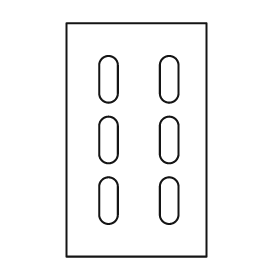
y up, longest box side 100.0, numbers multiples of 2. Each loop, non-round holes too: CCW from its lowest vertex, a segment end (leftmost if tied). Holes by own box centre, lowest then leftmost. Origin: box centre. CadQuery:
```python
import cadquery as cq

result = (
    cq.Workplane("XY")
    .moveTo(-30.0, -50.0)
    .lineTo(30.0, -50.0)
    .lineTo(30.0, 50.0)
    .lineTo(-30.0, 50.0)
    .close()
    .moveTo(-16.0, -32.0)
    .threePointArc((-12.0, -36.0), (-8.0, -32.0))
    .lineTo(-8.0, -20.0)
    .threePointArc((-12.0, -16.0), (-16.0, -20.0))
    .close()
    .moveTo(10.0, -32.0)
    .threePointArc((14.0, -36.0), (18.0, -32.0))
    .lineTo(18.0, -20.0)
    .threePointArc((14.0, -16.0), (10.0, -20.0))
    .close()
    .moveTo(-16.0, -6.0)
    .threePointArc((-12.0, -10.0), (-8.0, -6.0))
    .lineTo(-8.0, 6.0)
    .threePointArc((-12.0, 10.0), (-16.0, 6.0))
    .close()
    .moveTo(10.0, -6.0)
    .threePointArc((14.0, -10.0), (18.0, -6.0))
    .lineTo(18.0, 6.0)
    .threePointArc((14.0, 10.0), (10.0, 6.0))
    .close()
    .moveTo(-16.0, 20.0)
    .threePointArc((-12.0, 16.0), (-8.0, 20.0))
    .lineTo(-8.0, 32.0)
    .threePointArc((-12.0, 36.0), (-16.0, 32.0))
    .close()
    .moveTo(10.0, 20.0)
    .threePointArc((14.0, 16.0), (18.0, 20.0))
    .lineTo(18.0, 32.0)
    .threePointArc((14.0, 36.0), (10.0, 32.0))
    .close()
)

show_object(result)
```